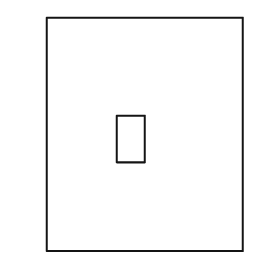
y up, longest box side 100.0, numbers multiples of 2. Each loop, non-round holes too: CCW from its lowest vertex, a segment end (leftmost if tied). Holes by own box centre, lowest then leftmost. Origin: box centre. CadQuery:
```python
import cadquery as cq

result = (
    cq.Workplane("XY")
    .moveTo(-42.0, -50.0)
    .lineTo(42.0, -50.0)
    .lineTo(42.0, 50.0)
    .lineTo(-42.0, 50.0)
    .close()
    .moveTo(-12.0, -12.0)
    .lineTo(0.0, -12.0)
    .lineTo(0.0, 8.0)
    .lineTo(-12.0, 8.0)
    .close()
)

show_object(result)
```